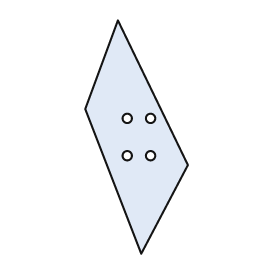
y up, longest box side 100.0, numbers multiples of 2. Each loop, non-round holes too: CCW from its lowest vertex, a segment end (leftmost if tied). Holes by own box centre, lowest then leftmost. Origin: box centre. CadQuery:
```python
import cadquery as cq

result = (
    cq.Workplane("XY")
    .moveTo(2.0, -50.0)
    .lineTo(22.0, -12.0)
    .lineTo(-8.0, 50.0)
    .lineTo(-22.0, 12.0)
    .close()
    .moveTo(-4.0, -8.0)
    .circle(2.0)
    .moveTo(6.0, -8.0)
    .circle(2.0)
    .moveTo(-4.0, 8.0)
    .circle(2.0)
    .moveTo(6.0, 8.0)
    .circle(2.0)
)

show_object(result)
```